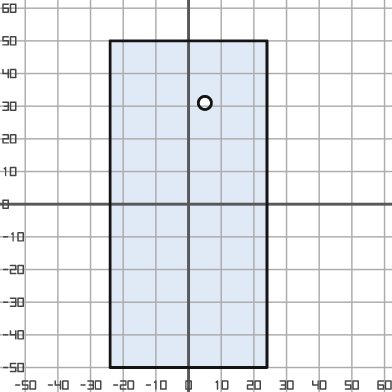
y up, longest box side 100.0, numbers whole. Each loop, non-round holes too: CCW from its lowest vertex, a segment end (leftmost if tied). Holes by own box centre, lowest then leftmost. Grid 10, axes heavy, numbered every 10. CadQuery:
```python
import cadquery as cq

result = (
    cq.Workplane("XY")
    .moveTo(-24.0, -50.0)
    .lineTo(24.0, -50.0)
    .lineTo(24.0, 50.0)
    .lineTo(-24.0, 50.0)
    .close()
    .moveTo(5.0, 31.0)
    .circle(2.0)
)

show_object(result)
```